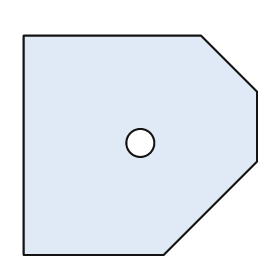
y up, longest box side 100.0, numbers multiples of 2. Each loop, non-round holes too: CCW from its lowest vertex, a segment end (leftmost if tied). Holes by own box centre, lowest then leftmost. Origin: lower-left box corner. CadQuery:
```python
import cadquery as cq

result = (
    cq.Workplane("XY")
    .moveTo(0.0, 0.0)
    .lineTo(60.0, 0.0)
    .lineTo(100.0, 40.0)
    .lineTo(100.0, 70.0)
    .lineTo(76.0, 94.0)
    .lineTo(0.0, 94.0)
    .close()
    .moveTo(50.0, 48.0)
    .circle(6.0)
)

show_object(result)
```